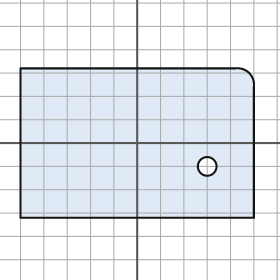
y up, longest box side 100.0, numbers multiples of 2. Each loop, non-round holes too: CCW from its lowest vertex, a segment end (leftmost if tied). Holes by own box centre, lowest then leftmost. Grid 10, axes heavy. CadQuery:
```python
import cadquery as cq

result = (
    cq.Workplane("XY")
    .moveTo(-50.0, -32.0)
    .lineTo(50.0, -32.0)
    .lineTo(50.0, 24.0)
    .threePointArc((48.0, 30.0), (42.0, 32.0))
    .lineTo(-50.0, 32.0)
    .close()
    .moveTo(30.0, -10.0)
    .circle(4.0)
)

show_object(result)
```